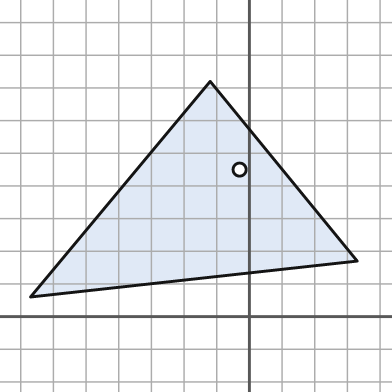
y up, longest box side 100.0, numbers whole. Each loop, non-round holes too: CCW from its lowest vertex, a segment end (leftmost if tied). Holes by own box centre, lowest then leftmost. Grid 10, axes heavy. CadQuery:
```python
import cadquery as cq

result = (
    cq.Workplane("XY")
    .moveTo(-67.0, 6.0)
    .lineTo(33.0, 17.0)
    .lineTo(-12.0, 72.0)
    .close()
    .moveTo(-3.0, 45.0)
    .circle(2.0)
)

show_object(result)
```